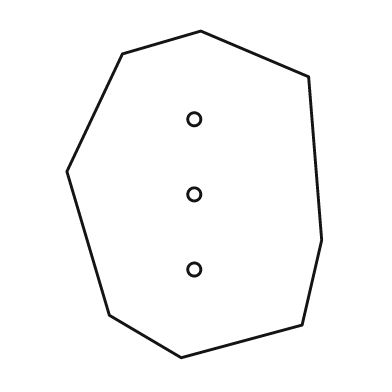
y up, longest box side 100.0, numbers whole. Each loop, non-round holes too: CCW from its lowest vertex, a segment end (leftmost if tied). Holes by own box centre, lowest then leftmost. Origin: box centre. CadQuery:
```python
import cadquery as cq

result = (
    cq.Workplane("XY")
    .moveTo(-4.0, -50.0)
    .lineTo(33.0, -40.0)
    .lineTo(39.0, -14.0)
    .lineTo(35.0, 36.0)
    .lineTo(2.0, 50.0)
    .lineTo(-22.0, 43.0)
    .lineTo(-39.0, 7.0)
    .lineTo(-26.0, -37.0)
    .close()
    .moveTo(0.0, -23.0)
    .circle(2.0)
    .moveTo(0.0, 0.0)
    .circle(2.0)
    .moveTo(0.0, 23.0)
    .circle(2.0)
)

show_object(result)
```